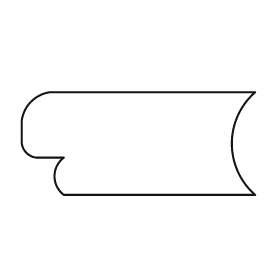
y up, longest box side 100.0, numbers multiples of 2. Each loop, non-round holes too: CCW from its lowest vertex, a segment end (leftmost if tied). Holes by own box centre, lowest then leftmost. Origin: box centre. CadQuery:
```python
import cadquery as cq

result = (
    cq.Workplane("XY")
    .moveTo(-32.0, -22.0)
    .lineTo(50.0, -22.0)
    .threePointArc((40.0, 0.0), (50.0, 22.0))
    .lineTo(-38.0, 22.0)
    .threePointArc((-46.0, 18.0), (-50.0, 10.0))
    .lineTo(-50.0, 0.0)
    .threePointArc((-48.0, -4.0), (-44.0, -6.0))
    .lineTo(-32.0, -6.0)
    .threePointArc((-36.0, -14.0), (-32.0, -22.0))
    .close()
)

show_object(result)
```